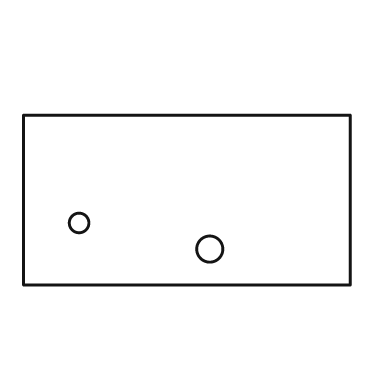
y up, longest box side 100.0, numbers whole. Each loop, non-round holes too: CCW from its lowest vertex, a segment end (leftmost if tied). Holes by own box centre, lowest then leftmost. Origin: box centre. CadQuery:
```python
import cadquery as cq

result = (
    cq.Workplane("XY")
    .moveTo(-50.0, -26.0)
    .lineTo(50.0, -26.0)
    .lineTo(50.0, 26.0)
    .lineTo(-50.0, 26.0)
    .close()
    .moveTo(7.0, -15.0)
    .circle(4.0)
    .moveTo(-33.0, -7.0)
    .circle(3.0)
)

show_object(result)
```